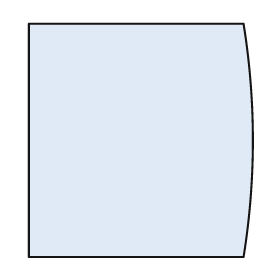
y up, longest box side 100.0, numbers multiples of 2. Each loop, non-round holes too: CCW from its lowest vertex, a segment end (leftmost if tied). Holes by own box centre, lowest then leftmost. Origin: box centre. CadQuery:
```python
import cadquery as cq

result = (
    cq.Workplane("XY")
    .moveTo(-48.0, -50.0)
    .lineTo(44.0, -50.0)
    .threePointArc((48.0, 0.0), (44.0, 50.0))
    .lineTo(-48.0, 50.0)
    .close()
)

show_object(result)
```